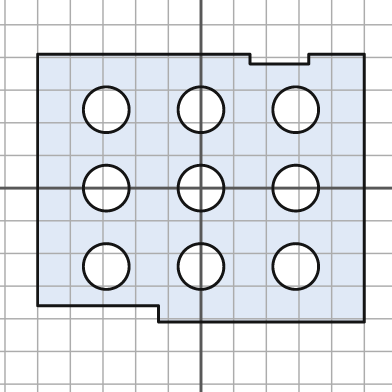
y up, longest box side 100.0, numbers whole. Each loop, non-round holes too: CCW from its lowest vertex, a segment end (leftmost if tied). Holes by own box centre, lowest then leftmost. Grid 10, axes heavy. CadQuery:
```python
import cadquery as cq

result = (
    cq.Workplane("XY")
    .moveTo(-13.0, -41.0)
    .lineTo(50.0, -41.0)
    .lineTo(50.0, 41.0)
    .lineTo(33.0, 41.0)
    .lineTo(33.0, 38.0)
    .lineTo(15.0, 38.0)
    .lineTo(15.0, 41.0)
    .lineTo(-50.0, 41.0)
    .lineTo(-50.0, -36.0)
    .lineTo(-13.0, -36.0)
    .close()
    .moveTo(-29.0, -24.0)
    .circle(7.0)
    .moveTo(0.0, -24.0)
    .circle(7.0)
    .moveTo(29.0, -24.0)
    .circle(7.0)
    .moveTo(-29.0, 0.0)
    .circle(7.0)
    .moveTo(0.0, 0.0)
    .circle(7.0)
    .moveTo(29.0, 0.0)
    .circle(7.0)
    .moveTo(-29.0, 24.0)
    .circle(7.0)
    .moveTo(0.0, 24.0)
    .circle(7.0)
    .moveTo(29.0, 24.0)
    .circle(7.0)
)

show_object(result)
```